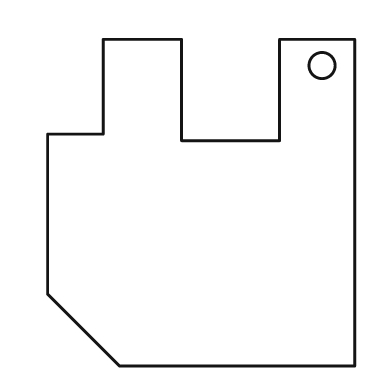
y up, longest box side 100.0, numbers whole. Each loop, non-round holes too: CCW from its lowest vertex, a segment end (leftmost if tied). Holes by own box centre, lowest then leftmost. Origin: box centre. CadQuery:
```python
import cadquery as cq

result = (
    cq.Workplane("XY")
    .moveTo(-25.0, -50.0)
    .lineTo(47.0, -50.0)
    .lineTo(47.0, 50.0)
    .lineTo(24.0, 50.0)
    .lineTo(24.0, 19.0)
    .lineTo(-6.0, 19.0)
    .lineTo(-6.0, 50.0)
    .lineTo(-30.0, 50.0)
    .lineTo(-30.0, 21.0)
    .lineTo(-47.0, 21.0)
    .lineTo(-47.0, -28.0)
    .close()
    .moveTo(37.0, 42.0)
    .circle(4.0)
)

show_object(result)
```